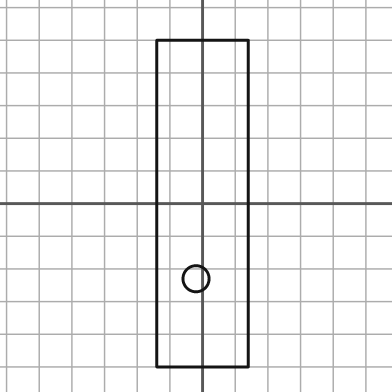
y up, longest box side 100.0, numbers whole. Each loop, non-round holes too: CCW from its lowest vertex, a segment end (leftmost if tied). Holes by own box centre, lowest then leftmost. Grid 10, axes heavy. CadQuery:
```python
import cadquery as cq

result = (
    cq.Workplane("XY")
    .moveTo(-14.0, -50.0)
    .lineTo(14.0, -50.0)
    .lineTo(14.0, 50.0)
    .lineTo(-14.0, 50.0)
    .close()
    .moveTo(-2.0, -23.0)
    .circle(4.0)
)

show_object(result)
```